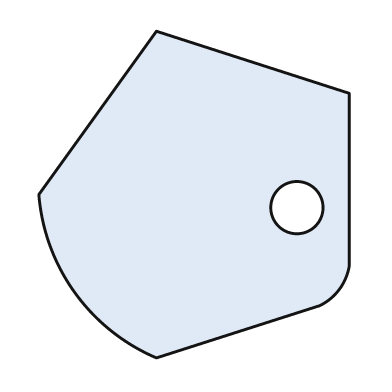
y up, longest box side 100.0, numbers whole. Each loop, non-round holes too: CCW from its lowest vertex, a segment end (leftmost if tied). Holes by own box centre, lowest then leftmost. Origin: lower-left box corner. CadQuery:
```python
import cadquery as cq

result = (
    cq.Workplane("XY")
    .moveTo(36.0, 0.0)
    .lineTo(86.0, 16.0)
    .threePointArc((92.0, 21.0), (95.0, 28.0))
    .lineTo(95.0, 81.0)
    .lineTo(36.0, 100.0)
    .lineTo(0.0, 50.0)
    .threePointArc((11.0, 20.0), (36.0, 0.0))
    .close()
    .moveTo(79.0, 46.0)
    .circle(8.0)
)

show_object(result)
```